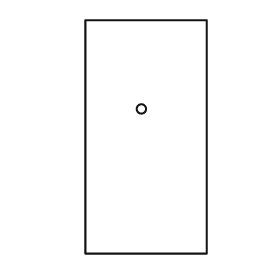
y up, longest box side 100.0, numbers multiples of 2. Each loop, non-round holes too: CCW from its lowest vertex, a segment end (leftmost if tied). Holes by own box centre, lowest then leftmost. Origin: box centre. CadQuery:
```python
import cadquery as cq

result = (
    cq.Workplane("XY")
    .moveTo(-26.0, -50.0)
    .lineTo(26.0, -50.0)
    .lineTo(26.0, 50.0)
    .lineTo(-26.0, 50.0)
    .close()
    .moveTo(-2.0, 12.0)
    .circle(2.0)
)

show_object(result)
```